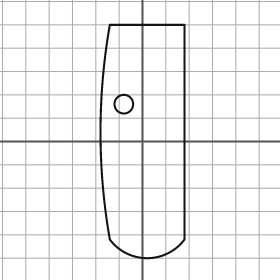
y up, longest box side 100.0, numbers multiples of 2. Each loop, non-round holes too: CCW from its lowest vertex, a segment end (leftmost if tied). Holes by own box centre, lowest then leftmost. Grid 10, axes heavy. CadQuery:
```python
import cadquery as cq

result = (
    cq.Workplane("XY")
    .moveTo(-14.0, -42.0)
    .threePointArc((2.0, -50.0), (18.0, -42.0))
    .lineTo(18.0, 50.0)
    .lineTo(-14.0, 50.0)
    .threePointArc((-18.0, 4.0), (-14.0, -42.0))
    .close()
    .moveTo(-8.0, 16.0)
    .circle(4.0)
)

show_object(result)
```